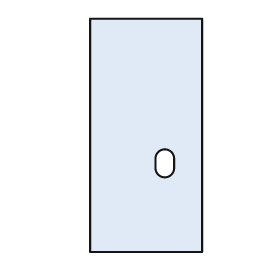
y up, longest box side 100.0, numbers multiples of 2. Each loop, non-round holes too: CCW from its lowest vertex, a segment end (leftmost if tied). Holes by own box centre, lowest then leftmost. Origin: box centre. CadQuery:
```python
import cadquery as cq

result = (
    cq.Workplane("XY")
    .moveTo(-24.0, -50.0)
    .lineTo(24.0, -50.0)
    .lineTo(24.0, 50.0)
    .lineTo(-24.0, 50.0)
    .close()
    .moveTo(4.0, -14.0)
    .threePointArc((8.0, -18.0), (12.0, -14.0))
    .lineTo(12.0, -10.0)
    .threePointArc((8.0, -6.0), (4.0, -10.0))
    .close()
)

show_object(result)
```